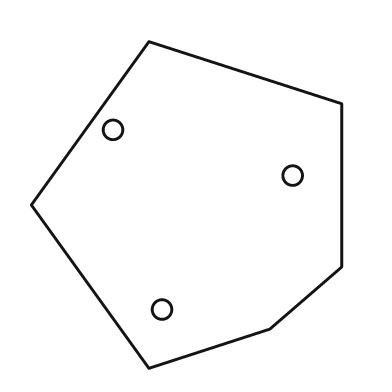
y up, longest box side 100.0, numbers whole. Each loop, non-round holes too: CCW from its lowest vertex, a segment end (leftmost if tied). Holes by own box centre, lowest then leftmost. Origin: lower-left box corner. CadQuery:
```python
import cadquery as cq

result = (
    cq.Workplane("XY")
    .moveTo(36.0, 0.0)
    .lineTo(73.0, 12.0)
    .lineTo(95.0, 31.0)
    .lineTo(95.0, 81.0)
    .lineTo(36.0, 100.0)
    .lineTo(0.0, 50.0)
    .close()
    .moveTo(40.0, 18.0)
    .circle(3.0)
    .moveTo(80.0, 59.0)
    .circle(3.0)
    .moveTo(25.0, 73.0)
    .circle(3.0)
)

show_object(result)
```